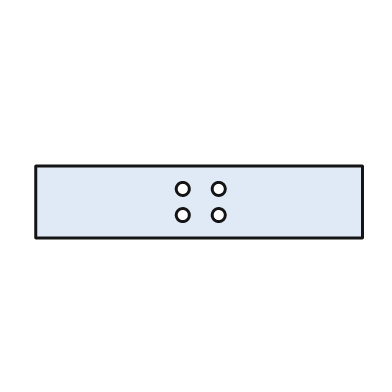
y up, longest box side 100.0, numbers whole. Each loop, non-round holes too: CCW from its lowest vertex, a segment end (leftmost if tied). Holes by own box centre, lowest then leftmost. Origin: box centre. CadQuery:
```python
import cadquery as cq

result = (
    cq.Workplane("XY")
    .moveTo(-50.0, -11.0)
    .lineTo(50.0, -11.0)
    .lineTo(50.0, 11.0)
    .lineTo(-50.0, 11.0)
    .close()
    .moveTo(-5.0, -4.0)
    .circle(2.0)
    .moveTo(6.0, -4.0)
    .circle(2.0)
    .moveTo(-5.0, 4.0)
    .circle(2.0)
    .moveTo(6.0, 4.0)
    .circle(2.0)
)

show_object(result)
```